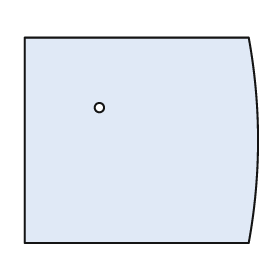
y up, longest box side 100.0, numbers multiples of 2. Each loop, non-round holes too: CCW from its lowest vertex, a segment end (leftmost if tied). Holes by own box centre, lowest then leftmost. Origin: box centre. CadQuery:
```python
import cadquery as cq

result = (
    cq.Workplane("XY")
    .moveTo(-50.0, -44.0)
    .lineTo(46.0, -44.0)
    .threePointArc((50.0, 0.0), (46.0, 44.0))
    .lineTo(-50.0, 44.0)
    .close()
    .moveTo(-18.0, 14.0)
    .circle(2.0)
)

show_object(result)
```